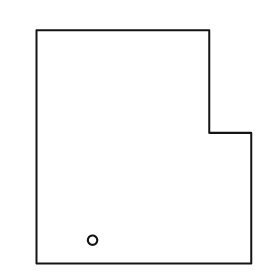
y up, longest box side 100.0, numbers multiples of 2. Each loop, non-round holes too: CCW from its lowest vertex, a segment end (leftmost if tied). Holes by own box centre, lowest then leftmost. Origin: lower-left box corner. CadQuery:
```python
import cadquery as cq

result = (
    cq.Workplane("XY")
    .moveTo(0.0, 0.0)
    .lineTo(92.0, 0.0)
    .lineTo(92.0, 56.0)
    .lineTo(74.0, 56.0)
    .lineTo(74.0, 100.0)
    .lineTo(0.0, 100.0)
    .close()
    .moveTo(24.0, 10.0)
    .circle(2.0)
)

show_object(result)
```